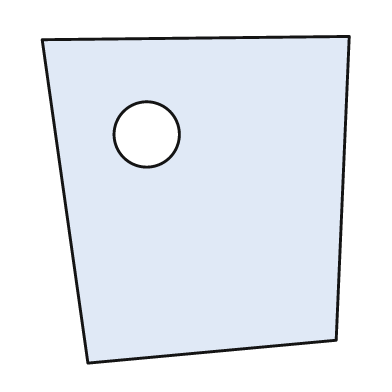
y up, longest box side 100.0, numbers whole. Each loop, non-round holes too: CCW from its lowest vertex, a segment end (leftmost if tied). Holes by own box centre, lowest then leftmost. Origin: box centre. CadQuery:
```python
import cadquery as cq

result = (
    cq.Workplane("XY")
    .moveTo(-33.0, -50.0)
    .lineTo(43.0, -43.0)
    .lineTo(47.0, 50.0)
    .lineTo(-47.0, 49.0)
    .close()
    .moveTo(-15.0, 20.0)
    .circle(10.0)
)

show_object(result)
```